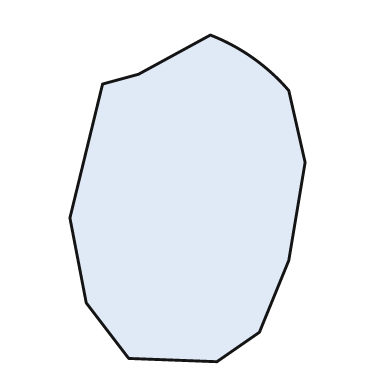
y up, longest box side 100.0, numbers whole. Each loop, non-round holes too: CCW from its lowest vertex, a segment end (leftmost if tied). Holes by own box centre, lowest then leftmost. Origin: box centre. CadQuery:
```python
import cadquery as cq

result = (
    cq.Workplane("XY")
    .moveTo(9.0, -50.0)
    .lineTo(22.0, -41.0)
    .lineTo(31.0, -19.0)
    .lineTo(36.0, 11.0)
    .lineTo(31.0, 33.0)
    .threePointArc((20.0, 43.0), (7.0, 50.0))
    .lineTo(-15.0, 38.0)
    .lineTo(-26.0, 35.0)
    .lineTo(-36.0, -6.0)
    .lineTo(-31.0, -32.0)
    .lineTo(-18.0, -49.0)
    .close()
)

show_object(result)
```